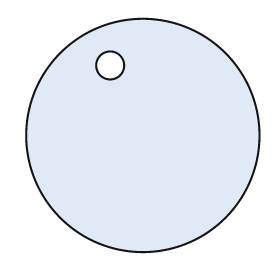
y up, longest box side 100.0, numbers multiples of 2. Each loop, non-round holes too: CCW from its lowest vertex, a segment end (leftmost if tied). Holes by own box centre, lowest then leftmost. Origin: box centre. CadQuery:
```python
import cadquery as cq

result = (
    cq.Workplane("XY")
    .moveTo(0.0, 0.0)
    .circle(50.0)
    .moveTo(-14.0, 30.0)
    .circle(6.0)
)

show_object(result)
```